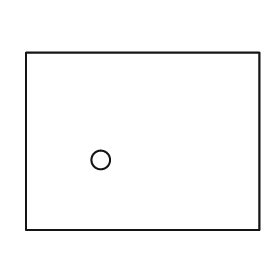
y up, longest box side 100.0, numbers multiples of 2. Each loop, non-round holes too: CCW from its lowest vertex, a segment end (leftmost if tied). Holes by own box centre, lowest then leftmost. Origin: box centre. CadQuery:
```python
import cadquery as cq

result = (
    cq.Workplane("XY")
    .moveTo(-50.0, -38.0)
    .lineTo(50.0, -38.0)
    .lineTo(50.0, 38.0)
    .lineTo(-50.0, 38.0)
    .close()
    .moveTo(-18.0, -8.0)
    .circle(4.0)
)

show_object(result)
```